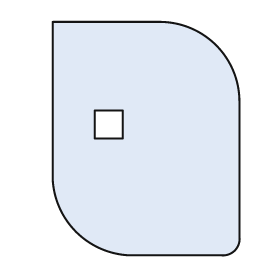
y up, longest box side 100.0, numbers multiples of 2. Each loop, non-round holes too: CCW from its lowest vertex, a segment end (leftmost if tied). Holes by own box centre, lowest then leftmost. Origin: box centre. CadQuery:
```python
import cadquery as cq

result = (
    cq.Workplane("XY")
    .moveTo(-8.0, -50.0)
    .lineTo(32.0, -50.0)
    .threePointArc((38.0, -48.0), (40.0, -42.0))
    .lineTo(40.0, 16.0)
    .threePointArc((30.0, 40.0), (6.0, 50.0))
    .lineTo(-40.0, 50.0)
    .lineTo(-40.0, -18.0)
    .threePointArc((-30.0, -40.0), (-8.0, -50.0))
    .close()
    .moveTo(-22.0, 0.0)
    .lineTo(-10.0, 0.0)
    .lineTo(-10.0, 12.0)
    .lineTo(-22.0, 12.0)
    .close()
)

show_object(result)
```